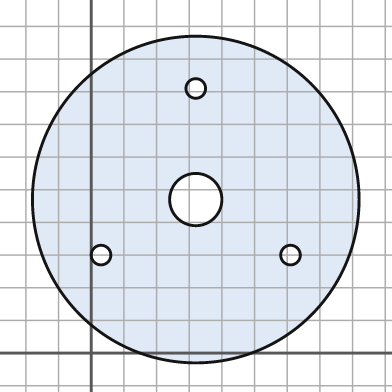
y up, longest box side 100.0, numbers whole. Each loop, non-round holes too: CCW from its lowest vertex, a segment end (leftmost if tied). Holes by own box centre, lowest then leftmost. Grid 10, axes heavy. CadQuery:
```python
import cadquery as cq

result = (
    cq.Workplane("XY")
    .moveTo(32.0, 47.0)
    .circle(50.0)
    .moveTo(3.0, 30.0)
    .circle(3.0)
    .moveTo(61.0, 30.0)
    .circle(3.0)
    .moveTo(32.0, 47.0)
    .circle(8.0)
    .moveTo(32.0, 81.0)
    .circle(3.0)
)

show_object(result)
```